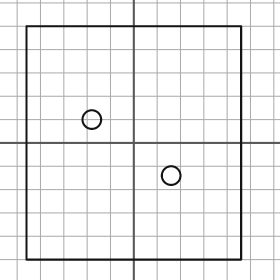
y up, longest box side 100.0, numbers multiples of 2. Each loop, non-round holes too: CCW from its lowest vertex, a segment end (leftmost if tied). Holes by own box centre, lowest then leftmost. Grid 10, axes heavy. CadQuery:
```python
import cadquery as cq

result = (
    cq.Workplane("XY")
    .moveTo(-46.0, -50.0)
    .lineTo(46.0, -50.0)
    .lineTo(46.0, 50.0)
    .lineTo(-46.0, 50.0)
    .close()
    .moveTo(16.0, -14.0)
    .circle(4.0)
    .moveTo(-18.0, 10.0)
    .circle(4.0)
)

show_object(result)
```